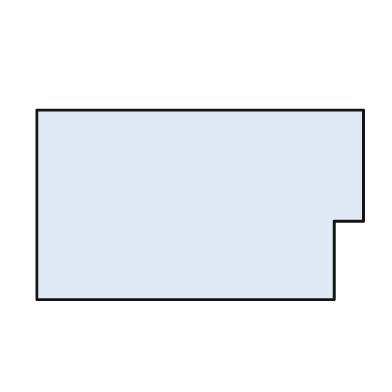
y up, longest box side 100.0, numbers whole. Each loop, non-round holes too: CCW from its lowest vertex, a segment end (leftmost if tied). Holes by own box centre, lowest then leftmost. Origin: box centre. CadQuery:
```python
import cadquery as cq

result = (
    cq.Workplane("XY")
    .moveTo(-50.0, -29.0)
    .lineTo(41.0, -29.0)
    .lineTo(41.0, -5.0)
    .lineTo(50.0, -5.0)
    .lineTo(50.0, 29.0)
    .lineTo(-50.0, 29.0)
    .close()
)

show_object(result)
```